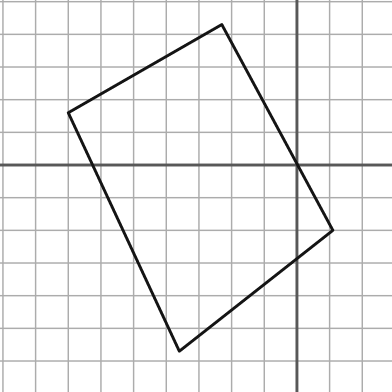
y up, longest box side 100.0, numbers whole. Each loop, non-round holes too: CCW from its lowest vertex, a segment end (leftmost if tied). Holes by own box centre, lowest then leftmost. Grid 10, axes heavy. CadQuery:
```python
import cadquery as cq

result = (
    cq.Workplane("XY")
    .moveTo(-36.0, -57.0)
    .lineTo(11.0, -20.0)
    .lineTo(-23.0, 43.0)
    .lineTo(-70.0, 16.0)
    .close()
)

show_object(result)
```